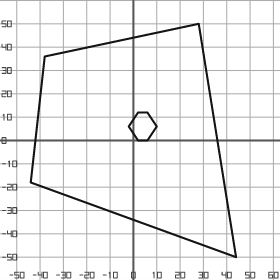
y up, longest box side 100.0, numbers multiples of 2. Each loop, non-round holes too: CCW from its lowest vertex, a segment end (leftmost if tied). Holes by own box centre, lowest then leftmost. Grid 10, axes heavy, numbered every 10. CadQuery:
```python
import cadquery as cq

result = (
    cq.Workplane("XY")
    .moveTo(44.0, -50.0)
    .lineTo(28.0, 50.0)
    .lineTo(-38.0, 36.0)
    .lineTo(-44.0, -18.0)
    .close()
    .moveTo(2.0, 0.0)
    .lineTo(6.0, 0.0)
    .lineTo(10.0, 6.0)
    .lineTo(6.0, 12.0)
    .lineTo(2.0, 12.0)
    .lineTo(-2.0, 6.0)
    .close()
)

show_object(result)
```